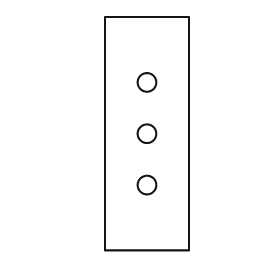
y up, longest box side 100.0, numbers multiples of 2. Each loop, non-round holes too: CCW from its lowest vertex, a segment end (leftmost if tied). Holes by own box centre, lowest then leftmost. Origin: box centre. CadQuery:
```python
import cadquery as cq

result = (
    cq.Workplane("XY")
    .moveTo(-18.0, -50.0)
    .lineTo(18.0, -50.0)
    .lineTo(18.0, 50.0)
    .lineTo(-18.0, 50.0)
    .close()
    .moveTo(0.0, -22.0)
    .circle(4.0)
    .moveTo(0.0, 0.0)
    .circle(4.0)
    .moveTo(0.0, 22.0)
    .circle(4.0)
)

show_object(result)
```